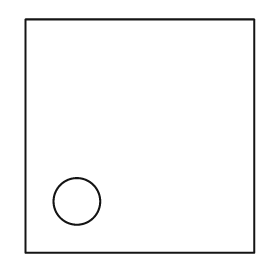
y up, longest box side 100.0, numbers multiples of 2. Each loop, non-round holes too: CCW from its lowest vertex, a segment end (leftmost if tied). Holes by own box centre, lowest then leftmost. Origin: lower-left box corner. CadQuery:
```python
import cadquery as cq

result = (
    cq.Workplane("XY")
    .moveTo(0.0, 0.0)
    .lineTo(98.0, 0.0)
    .lineTo(98.0, 100.0)
    .lineTo(0.0, 100.0)
    .close()
    .moveTo(22.0, 22.0)
    .circle(10.0)
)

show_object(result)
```